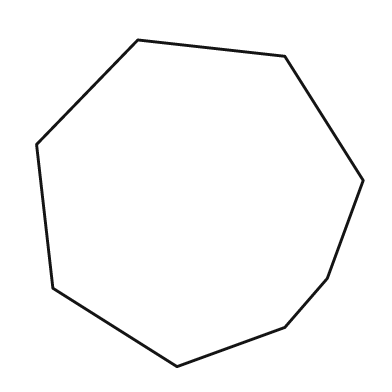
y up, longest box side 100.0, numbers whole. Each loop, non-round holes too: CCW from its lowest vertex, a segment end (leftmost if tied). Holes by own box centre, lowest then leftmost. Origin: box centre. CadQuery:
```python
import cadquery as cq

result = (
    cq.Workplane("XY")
    .moveTo(-7.0, -50.0)
    .lineTo(26.0, -38.0)
    .lineTo(39.0, -23.0)
    .lineTo(50.0, 7.0)
    .lineTo(26.0, 45.0)
    .lineTo(-19.0, 50.0)
    .lineTo(-50.0, 18.0)
    .lineTo(-45.0, -26.0)
    .close()
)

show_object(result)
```